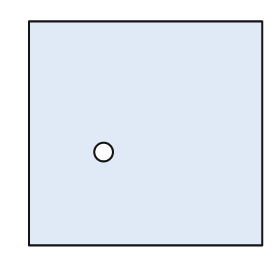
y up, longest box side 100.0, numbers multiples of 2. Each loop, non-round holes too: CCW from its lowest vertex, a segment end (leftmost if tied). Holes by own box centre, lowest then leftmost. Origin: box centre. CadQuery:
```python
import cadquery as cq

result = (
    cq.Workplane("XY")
    .moveTo(-50.0, -48.0)
    .lineTo(50.0, -48.0)
    .lineTo(50.0, 48.0)
    .lineTo(-50.0, 48.0)
    .close()
    .moveTo(-18.0, -8.0)
    .circle(4.0)
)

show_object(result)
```